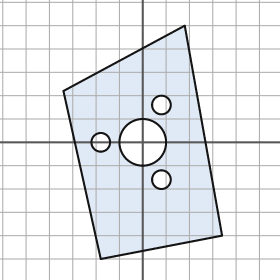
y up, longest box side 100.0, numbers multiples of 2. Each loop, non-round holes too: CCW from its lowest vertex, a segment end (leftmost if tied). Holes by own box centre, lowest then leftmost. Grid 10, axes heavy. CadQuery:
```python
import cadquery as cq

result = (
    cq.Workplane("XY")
    .moveTo(-18.0, -50.0)
    .lineTo(34.0, -40.0)
    .lineTo(18.0, 50.0)
    .lineTo(-34.0, 22.0)
    .close()
    .moveTo(8.0, -16.0)
    .circle(4.0)
    .moveTo(-18.0, 0.0)
    .circle(4.0)
    .moveTo(0.0, 0.0)
    .circle(10.0)
    .moveTo(8.0, 16.0)
    .circle(4.0)
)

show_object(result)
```